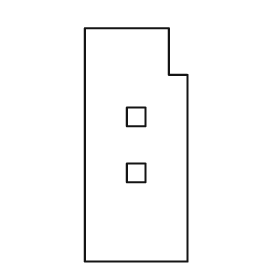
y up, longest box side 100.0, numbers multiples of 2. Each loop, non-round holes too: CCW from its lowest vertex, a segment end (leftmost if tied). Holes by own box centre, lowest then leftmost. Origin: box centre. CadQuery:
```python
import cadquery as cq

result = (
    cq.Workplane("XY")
    .moveTo(-22.0, -50.0)
    .lineTo(22.0, -50.0)
    .lineTo(22.0, 30.0)
    .lineTo(14.0, 30.0)
    .lineTo(14.0, 50.0)
    .lineTo(-22.0, 50.0)
    .close()
    .moveTo(-4.0, -16.0)
    .lineTo(4.0, -16.0)
    .lineTo(4.0, -8.0)
    .lineTo(-4.0, -8.0)
    .close()
    .moveTo(-4.0, 8.0)
    .lineTo(4.0, 8.0)
    .lineTo(4.0, 16.0)
    .lineTo(-4.0, 16.0)
    .close()
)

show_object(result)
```